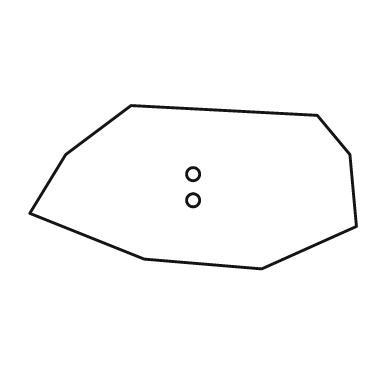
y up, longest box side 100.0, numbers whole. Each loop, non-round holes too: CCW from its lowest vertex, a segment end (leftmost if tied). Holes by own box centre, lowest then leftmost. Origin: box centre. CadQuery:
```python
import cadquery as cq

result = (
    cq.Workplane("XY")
    .moveTo(21.0, -25.0)
    .lineTo(50.0, -12.0)
    .lineTo(48.0, 10.0)
    .lineTo(38.0, 22.0)
    .lineTo(-19.0, 25.0)
    .lineTo(-39.0, 10.0)
    .lineTo(-50.0, -8.0)
    .lineTo(-15.0, -22.0)
    .close()
    .moveTo(0.0, -4.0)
    .circle(2.0)
    .moveTo(0.0, 4.0)
    .circle(2.0)
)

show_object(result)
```